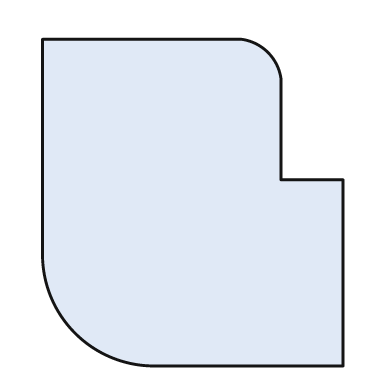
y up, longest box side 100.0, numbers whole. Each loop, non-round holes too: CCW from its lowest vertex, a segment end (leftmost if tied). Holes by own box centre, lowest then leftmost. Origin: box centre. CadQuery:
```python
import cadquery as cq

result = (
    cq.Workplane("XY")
    .moveTo(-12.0, -50.0)
    .lineTo(46.0, -50.0)
    .lineTo(46.0, 7.0)
    .lineTo(27.0, 7.0)
    .lineTo(27.0, 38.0)
    .threePointArc((23.0, 46.0), (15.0, 50.0))
    .lineTo(-46.0, 50.0)
    .lineTo(-46.0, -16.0)
    .threePointArc((-36.0, -40.0), (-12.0, -50.0))
    .close()
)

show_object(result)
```